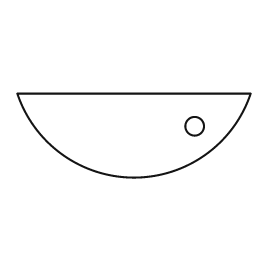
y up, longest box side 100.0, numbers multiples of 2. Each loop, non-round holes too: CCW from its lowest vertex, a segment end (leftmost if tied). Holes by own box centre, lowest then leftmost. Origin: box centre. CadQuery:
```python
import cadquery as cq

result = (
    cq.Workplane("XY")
    .moveTo(-50.0, 18.0)
    .threePointArc((0.0, -18.0), (50.0, 18.0))
    .close()
    .moveTo(26.0, 4.0)
    .circle(4.0)
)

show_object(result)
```